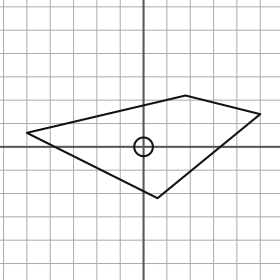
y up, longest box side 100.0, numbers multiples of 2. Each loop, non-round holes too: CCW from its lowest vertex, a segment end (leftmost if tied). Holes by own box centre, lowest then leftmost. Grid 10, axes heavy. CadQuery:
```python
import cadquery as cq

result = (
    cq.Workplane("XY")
    .moveTo(6.0, -22.0)
    .lineTo(50.0, 14.0)
    .lineTo(18.0, 22.0)
    .lineTo(-50.0, 6.0)
    .close()
    .moveTo(0.0, 0.0)
    .circle(4.0)
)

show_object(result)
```